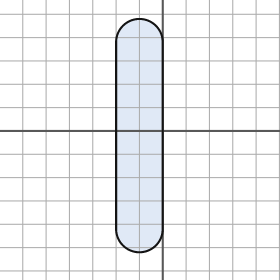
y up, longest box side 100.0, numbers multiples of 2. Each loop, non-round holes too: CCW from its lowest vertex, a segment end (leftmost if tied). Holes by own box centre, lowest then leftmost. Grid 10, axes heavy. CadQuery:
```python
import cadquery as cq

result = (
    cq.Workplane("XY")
    .moveTo(-20.0, -42.0)
    .threePointArc((-10.0, -52.0), (0.0, -42.0))
    .lineTo(0.0, 38.0)
    .threePointArc((-10.0, 48.0), (-20.0, 38.0))
    .close()
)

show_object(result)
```